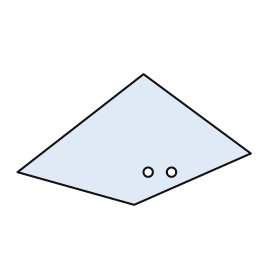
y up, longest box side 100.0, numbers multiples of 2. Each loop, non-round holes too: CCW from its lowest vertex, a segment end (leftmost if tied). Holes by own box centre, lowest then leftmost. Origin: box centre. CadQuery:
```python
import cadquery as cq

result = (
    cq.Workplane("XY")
    .moveTo(0.0, -28.0)
    .lineTo(50.0, -6.0)
    .lineTo(4.0, 28.0)
    .lineTo(-50.0, -14.0)
    .close()
    .moveTo(6.0, -14.0)
    .circle(2.0)
    .moveTo(16.0, -14.0)
    .circle(2.0)
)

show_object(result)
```